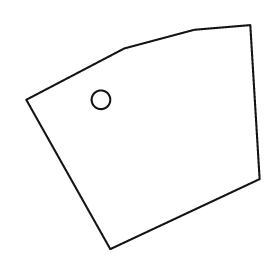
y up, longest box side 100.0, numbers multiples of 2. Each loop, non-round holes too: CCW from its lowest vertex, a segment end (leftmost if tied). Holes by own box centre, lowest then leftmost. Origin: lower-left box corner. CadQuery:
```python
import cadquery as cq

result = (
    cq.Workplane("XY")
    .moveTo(36.0, 0.0)
    .lineTo(100.0, 30.0)
    .lineTo(96.0, 96.0)
    .lineTo(72.0, 94.0)
    .lineTo(42.0, 86.0)
    .lineTo(0.0, 64.0)
    .close()
    .moveTo(32.0, 64.0)
    .circle(4.0)
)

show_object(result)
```